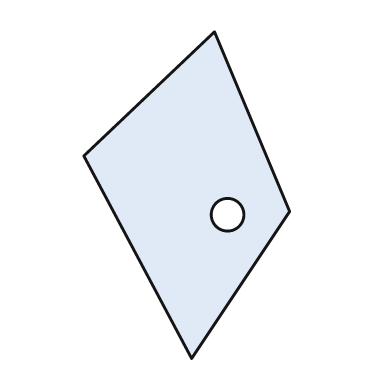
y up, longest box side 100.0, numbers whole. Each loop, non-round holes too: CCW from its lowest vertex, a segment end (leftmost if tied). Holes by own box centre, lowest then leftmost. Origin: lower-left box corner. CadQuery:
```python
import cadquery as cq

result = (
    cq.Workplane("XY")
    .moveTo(33.0, 0.0)
    .lineTo(63.0, 45.0)
    .lineTo(40.0, 100.0)
    .lineTo(0.0, 62.0)
    .close()
    .moveTo(44.0, 44.0)
    .circle(5.0)
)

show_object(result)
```